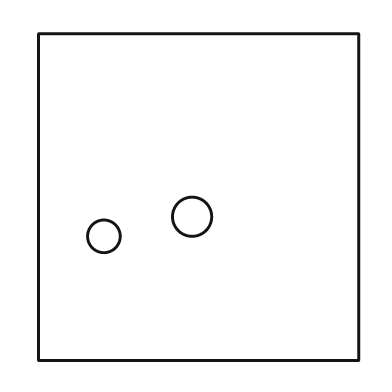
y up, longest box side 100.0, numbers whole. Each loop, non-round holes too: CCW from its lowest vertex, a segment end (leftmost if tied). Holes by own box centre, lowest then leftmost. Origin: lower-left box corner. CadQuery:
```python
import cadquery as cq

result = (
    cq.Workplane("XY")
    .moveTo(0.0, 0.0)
    .lineTo(98.0, 0.0)
    .lineTo(98.0, 100.0)
    .lineTo(0.0, 100.0)
    .close()
    .moveTo(20.0, 38.0)
    .circle(5.0)
    .moveTo(47.0, 44.0)
    .circle(6.0)
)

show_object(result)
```